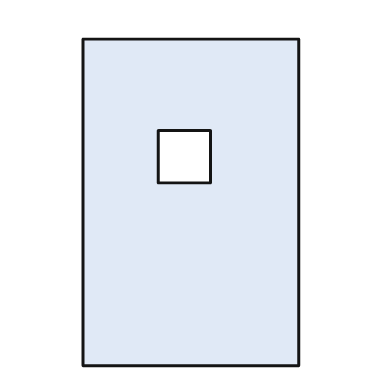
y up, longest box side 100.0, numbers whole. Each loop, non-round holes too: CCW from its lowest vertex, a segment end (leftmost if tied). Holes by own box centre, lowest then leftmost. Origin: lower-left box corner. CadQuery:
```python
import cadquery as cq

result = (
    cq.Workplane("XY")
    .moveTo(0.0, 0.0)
    .lineTo(66.0, 0.0)
    .lineTo(66.0, 100.0)
    .lineTo(0.0, 100.0)
    .close()
    .moveTo(23.0, 56.0)
    .lineTo(39.0, 56.0)
    .lineTo(39.0, 72.0)
    .lineTo(23.0, 72.0)
    .close()
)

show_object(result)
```